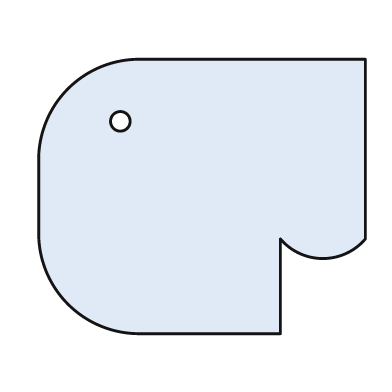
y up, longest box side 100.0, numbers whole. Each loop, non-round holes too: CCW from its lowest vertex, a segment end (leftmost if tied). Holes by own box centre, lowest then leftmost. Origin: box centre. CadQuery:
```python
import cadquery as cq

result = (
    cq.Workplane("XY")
    .moveTo(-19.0, -42.0)
    .lineTo(24.0, -42.0)
    .lineTo(24.0, -13.0)
    .threePointArc((37.0, -19.0), (50.0, -13.0))
    .lineTo(50.0, 42.0)
    .lineTo(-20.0, 42.0)
    .threePointArc((-41.0, 33.0), (-50.0, 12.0))
    .lineTo(-50.0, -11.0)
    .threePointArc((-41.0, -33.0), (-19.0, -42.0))
    .close()
    .moveTo(-25.0, 23.0)
    .circle(3.0)
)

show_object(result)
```